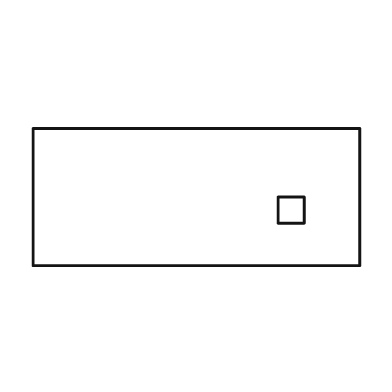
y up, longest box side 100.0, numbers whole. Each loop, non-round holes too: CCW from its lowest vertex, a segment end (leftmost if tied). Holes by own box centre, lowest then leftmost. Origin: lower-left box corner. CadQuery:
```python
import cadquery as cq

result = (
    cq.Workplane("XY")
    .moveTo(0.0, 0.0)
    .lineTo(100.0, 0.0)
    .lineTo(100.0, 42.0)
    .lineTo(0.0, 42.0)
    .close()
    .moveTo(75.0, 13.0)
    .lineTo(83.0, 13.0)
    .lineTo(83.0, 21.0)
    .lineTo(75.0, 21.0)
    .close()
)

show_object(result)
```